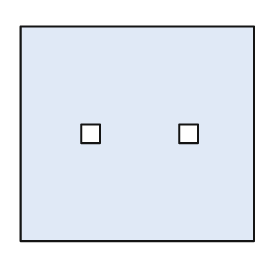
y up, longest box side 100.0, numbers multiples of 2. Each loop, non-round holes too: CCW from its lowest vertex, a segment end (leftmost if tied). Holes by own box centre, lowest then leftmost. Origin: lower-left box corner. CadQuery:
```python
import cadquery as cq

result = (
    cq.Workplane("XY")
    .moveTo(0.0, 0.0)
    .lineTo(100.0, 0.0)
    .lineTo(100.0, 92.0)
    .lineTo(0.0, 92.0)
    .close()
    .moveTo(26.0, 42.0)
    .lineTo(34.0, 42.0)
    .lineTo(34.0, 50.0)
    .lineTo(26.0, 50.0)
    .close()
    .moveTo(68.0, 42.0)
    .lineTo(76.0, 42.0)
    .lineTo(76.0, 50.0)
    .lineTo(68.0, 50.0)
    .close()
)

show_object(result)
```